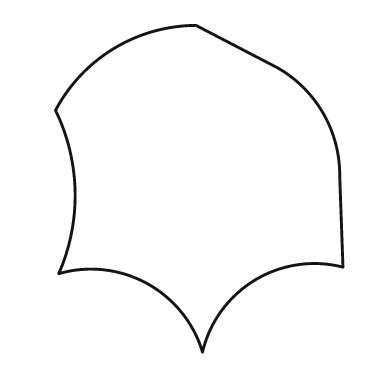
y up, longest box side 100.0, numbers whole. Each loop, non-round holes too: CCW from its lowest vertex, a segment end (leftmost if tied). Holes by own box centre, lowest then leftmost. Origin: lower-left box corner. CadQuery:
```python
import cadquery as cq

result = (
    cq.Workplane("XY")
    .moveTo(45.0, 0.0)
    .threePointArc((61.0, 22.0), (88.0, 26.0))
    .lineTo(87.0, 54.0)
    .threePointArc((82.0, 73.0), (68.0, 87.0))
    .lineTo(43.0, 100.0)
    .threePointArc((18.0, 93.0), (0.0, 74.0))
    .threePointArc((6.0, 49.0), (1.0, 24.0))
    .threePointArc((28.0, 21.0), (45.0, 0.0))
    .close()
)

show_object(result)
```